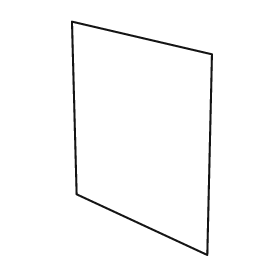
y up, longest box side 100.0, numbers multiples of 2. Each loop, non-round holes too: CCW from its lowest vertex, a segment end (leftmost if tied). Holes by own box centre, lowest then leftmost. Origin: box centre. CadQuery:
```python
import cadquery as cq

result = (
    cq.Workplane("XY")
    .moveTo(28.0, -50.0)
    .lineTo(30.0, 36.0)
    .lineTo(-30.0, 50.0)
    .lineTo(-28.0, -24.0)
    .close()
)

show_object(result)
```